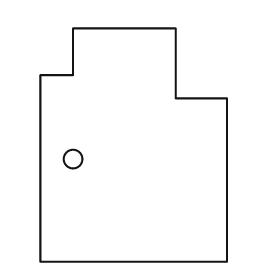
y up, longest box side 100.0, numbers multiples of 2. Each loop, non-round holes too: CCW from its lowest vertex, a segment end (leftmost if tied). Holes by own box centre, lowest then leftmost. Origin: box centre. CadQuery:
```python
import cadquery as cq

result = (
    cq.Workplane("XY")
    .moveTo(-40.0, -50.0)
    .lineTo(40.0, -50.0)
    .lineTo(40.0, 20.0)
    .lineTo(18.0, 20.0)
    .lineTo(18.0, 50.0)
    .lineTo(-26.0, 50.0)
    .lineTo(-26.0, 30.0)
    .lineTo(-40.0, 30.0)
    .close()
    .moveTo(-26.0, -6.0)
    .circle(4.0)
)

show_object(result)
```